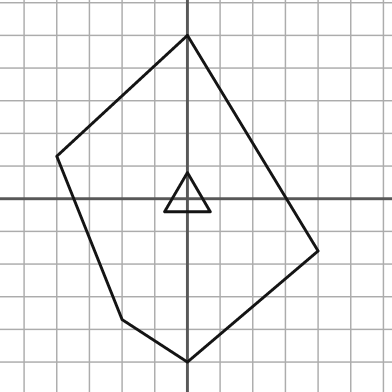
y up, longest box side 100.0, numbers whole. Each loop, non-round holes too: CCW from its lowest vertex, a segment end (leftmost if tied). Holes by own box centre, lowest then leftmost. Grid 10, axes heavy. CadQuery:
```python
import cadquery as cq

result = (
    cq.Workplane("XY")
    .moveTo(0.0, -50.0)
    .lineTo(40.0, -16.0)
    .lineTo(0.0, 50.0)
    .lineTo(-40.0, 13.0)
    .lineTo(-20.0, -37.0)
    .close()
    .moveTo(-7.0, -4.0)
    .lineTo(7.0, -4.0)
    .lineTo(0.0, 8.0)
    .close()
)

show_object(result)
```